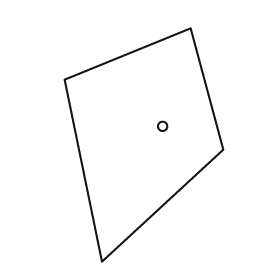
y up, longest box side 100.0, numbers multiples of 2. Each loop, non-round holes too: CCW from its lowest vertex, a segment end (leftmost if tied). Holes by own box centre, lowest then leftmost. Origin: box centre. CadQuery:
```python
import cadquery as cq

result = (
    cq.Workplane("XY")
    .moveTo(-18.0, -50.0)
    .lineTo(34.0, -2.0)
    .lineTo(20.0, 50.0)
    .lineTo(-34.0, 28.0)
    .close()
    .moveTo(8.0, 8.0)
    .circle(2.0)
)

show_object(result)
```